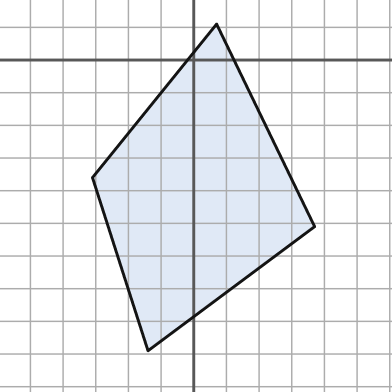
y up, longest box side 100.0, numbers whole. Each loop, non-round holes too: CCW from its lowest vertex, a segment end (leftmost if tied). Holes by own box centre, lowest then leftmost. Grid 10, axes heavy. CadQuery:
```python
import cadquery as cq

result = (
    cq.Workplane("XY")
    .moveTo(-14.0, -89.0)
    .lineTo(37.0, -51.0)
    .lineTo(7.0, 11.0)
    .lineTo(-31.0, -36.0)
    .close()
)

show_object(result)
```